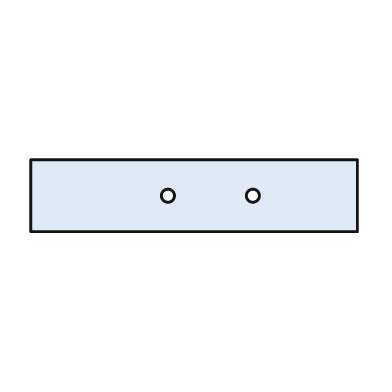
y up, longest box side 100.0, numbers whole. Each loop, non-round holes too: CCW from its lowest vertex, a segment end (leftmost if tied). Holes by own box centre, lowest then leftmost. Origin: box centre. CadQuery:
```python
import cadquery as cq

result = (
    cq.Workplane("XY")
    .moveTo(-50.0, -11.0)
    .lineTo(50.0, -11.0)
    .lineTo(50.0, 11.0)
    .lineTo(-50.0, 11.0)
    .close()
    .moveTo(-8.0, 0.0)
    .circle(2.0)
    .moveTo(18.0, 0.0)
    .circle(2.0)
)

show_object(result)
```